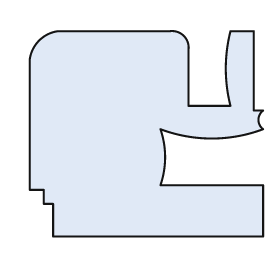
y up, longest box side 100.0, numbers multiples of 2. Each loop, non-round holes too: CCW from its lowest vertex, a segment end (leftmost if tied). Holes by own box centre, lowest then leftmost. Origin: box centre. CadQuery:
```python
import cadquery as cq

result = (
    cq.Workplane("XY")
    .moveTo(-40.0, -44.0)
    .lineTo(50.0, -44.0)
    .lineTo(50.0, -22.0)
    .lineTo(6.0, -22.0)
    .threePointArc((8.0, -10.0), (6.0, 2.0))
    .threePointArc((28.0, -2.0), (50.0, 2.0))
    .threePointArc((48.0, 6.0), (50.0, 10.0))
    .lineTo(46.0, 10.0)
    .lineTo(46.0, 44.0)
    .lineTo(36.0, 44.0)
    .threePointArc((34.0, 28.0), (36.0, 12.0))
    .lineTo(18.0, 12.0)
    .lineTo(18.0, 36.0)
    .threePointArc((16.0, 42.0), (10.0, 44.0))
    .lineTo(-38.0, 44.0)
    .threePointArc((-46.0, 40.0), (-50.0, 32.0))
    .lineTo(-50.0, -24.0)
    .lineTo(-44.0, -24.0)
    .lineTo(-44.0, -30.0)
    .lineTo(-40.0, -30.0)
    .close()
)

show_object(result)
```